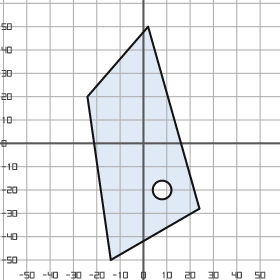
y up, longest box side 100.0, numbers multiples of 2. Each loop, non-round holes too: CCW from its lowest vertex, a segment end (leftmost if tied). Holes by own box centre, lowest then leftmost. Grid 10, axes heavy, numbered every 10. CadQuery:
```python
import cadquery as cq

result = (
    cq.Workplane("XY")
    .moveTo(-14.0, -50.0)
    .lineTo(24.0, -28.0)
    .lineTo(2.0, 50.0)
    .lineTo(-24.0, 20.0)
    .close()
    .moveTo(8.0, -20.0)
    .circle(4.0)
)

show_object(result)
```